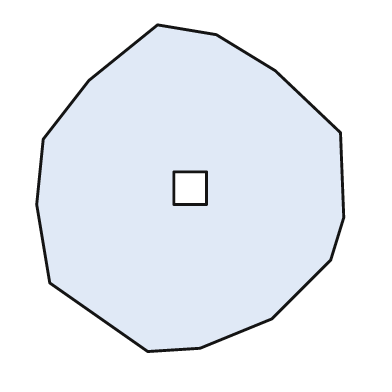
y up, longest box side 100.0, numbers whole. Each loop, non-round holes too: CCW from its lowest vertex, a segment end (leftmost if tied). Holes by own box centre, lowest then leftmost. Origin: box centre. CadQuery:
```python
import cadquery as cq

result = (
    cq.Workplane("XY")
    .moveTo(-13.0, -50.0)
    .lineTo(3.0, -49.0)
    .lineTo(25.0, -40.0)
    .lineTo(43.0, -22.0)
    .lineTo(47.0, -9.0)
    .lineTo(46.0, 17.0)
    .lineTo(26.0, 36.0)
    .lineTo(8.0, 47.0)
    .lineTo(-10.0, 50.0)
    .lineTo(-31.0, 33.0)
    .lineTo(-45.0, 15.0)
    .lineTo(-47.0, -5.0)
    .lineTo(-43.0, -29.0)
    .close()
    .moveTo(-5.0, -5.0)
    .lineTo(5.0, -5.0)
    .lineTo(5.0, 5.0)
    .lineTo(-5.0, 5.0)
    .close()
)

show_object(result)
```